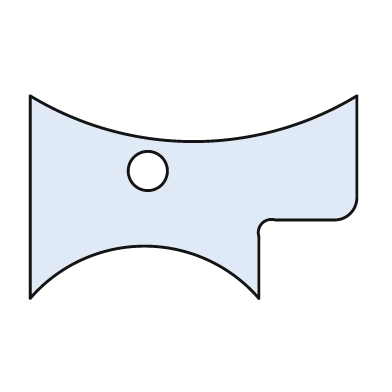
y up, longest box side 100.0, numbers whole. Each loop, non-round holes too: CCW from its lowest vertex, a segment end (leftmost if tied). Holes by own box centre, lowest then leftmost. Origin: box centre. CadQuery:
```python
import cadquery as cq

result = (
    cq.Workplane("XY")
    .moveTo(-50.0, -31.0)
    .threePointArc((-15.0, -15.0), (20.0, -31.0))
    .lineTo(20.0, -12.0)
    .threePointArc((21.0, -8.0), (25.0, -7.0))
    .lineTo(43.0, -7.0)
    .threePointArc((48.0, -5.0), (50.0, 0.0))
    .lineTo(50.0, 31.0)
    .threePointArc((0.0, 17.0), (-50.0, 31.0))
    .close()
    .moveTo(-14.0, 8.0)
    .circle(6.0)
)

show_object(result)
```